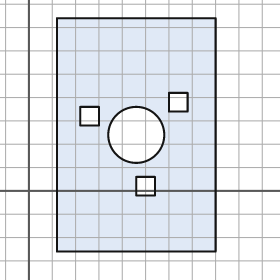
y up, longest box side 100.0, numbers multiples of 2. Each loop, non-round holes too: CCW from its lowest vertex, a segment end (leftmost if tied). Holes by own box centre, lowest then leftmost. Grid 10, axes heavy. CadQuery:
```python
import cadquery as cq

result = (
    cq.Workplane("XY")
    .moveTo(12.0, -26.0)
    .lineTo(80.0, -26.0)
    .lineTo(80.0, 74.0)
    .lineTo(12.0, 74.0)
    .close()
    .moveTo(46.0, -2.0)
    .lineTo(54.0, -2.0)
    .lineTo(54.0, 6.0)
    .lineTo(46.0, 6.0)
    .close()
    .moveTo(46.0, 24.0)
    .circle(12.0)
    .moveTo(22.0, 28.0)
    .lineTo(30.0, 28.0)
    .lineTo(30.0, 36.0)
    .lineTo(22.0, 36.0)
    .close()
    .moveTo(60.0, 34.0)
    .lineTo(68.0, 34.0)
    .lineTo(68.0, 42.0)
    .lineTo(60.0, 42.0)
    .close()
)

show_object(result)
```